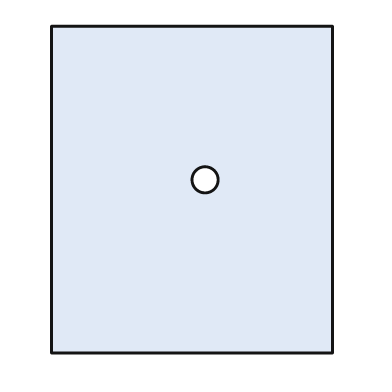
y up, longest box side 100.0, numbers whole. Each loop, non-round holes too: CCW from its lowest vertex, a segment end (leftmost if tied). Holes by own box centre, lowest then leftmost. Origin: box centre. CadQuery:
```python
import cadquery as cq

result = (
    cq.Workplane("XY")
    .moveTo(-43.0, -50.0)
    .lineTo(43.0, -50.0)
    .lineTo(43.0, 50.0)
    .lineTo(-43.0, 50.0)
    .close()
    .moveTo(4.0, 3.0)
    .circle(4.0)
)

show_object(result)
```